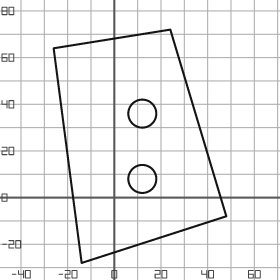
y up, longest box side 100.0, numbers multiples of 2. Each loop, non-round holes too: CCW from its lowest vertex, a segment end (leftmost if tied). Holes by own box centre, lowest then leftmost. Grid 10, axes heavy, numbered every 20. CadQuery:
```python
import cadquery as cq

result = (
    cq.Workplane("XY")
    .moveTo(-14.0, -28.0)
    .lineTo(48.0, -8.0)
    .lineTo(24.0, 72.0)
    .lineTo(-26.0, 64.0)
    .close()
    .moveTo(12.0, 8.0)
    .circle(6.0)
    .moveTo(12.0, 36.0)
    .circle(6.0)
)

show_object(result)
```